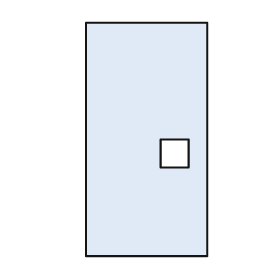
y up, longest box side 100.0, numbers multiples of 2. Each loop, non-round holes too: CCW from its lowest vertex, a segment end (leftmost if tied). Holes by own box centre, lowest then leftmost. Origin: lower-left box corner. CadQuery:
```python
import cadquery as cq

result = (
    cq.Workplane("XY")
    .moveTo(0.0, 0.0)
    .lineTo(52.0, 0.0)
    .lineTo(52.0, 100.0)
    .lineTo(0.0, 100.0)
    .close()
    .moveTo(32.0, 38.0)
    .lineTo(44.0, 38.0)
    .lineTo(44.0, 50.0)
    .lineTo(32.0, 50.0)
    .close()
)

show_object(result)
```